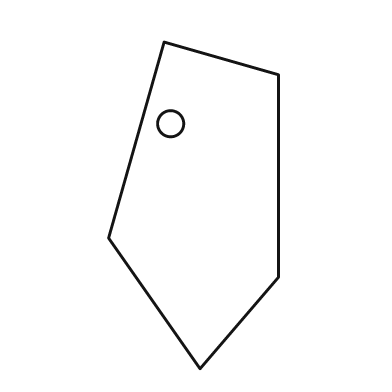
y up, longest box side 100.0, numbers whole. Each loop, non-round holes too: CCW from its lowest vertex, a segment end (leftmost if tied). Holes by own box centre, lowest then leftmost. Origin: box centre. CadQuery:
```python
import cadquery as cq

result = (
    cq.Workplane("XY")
    .moveTo(2.0, -50.0)
    .lineTo(26.0, -22.0)
    .lineTo(26.0, 40.0)
    .lineTo(-9.0, 50.0)
    .lineTo(-26.0, -10.0)
    .close()
    .moveTo(-7.0, 25.0)
    .circle(4.0)
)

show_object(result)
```